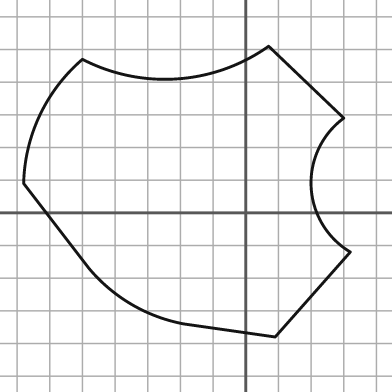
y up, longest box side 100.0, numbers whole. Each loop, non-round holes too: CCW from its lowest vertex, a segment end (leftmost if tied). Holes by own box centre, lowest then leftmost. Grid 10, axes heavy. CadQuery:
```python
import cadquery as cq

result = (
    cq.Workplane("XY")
    .moveTo(9.0, -38.0)
    .lineTo(32.0, -12.0)
    .threePointArc((20.0, 8.0), (30.0, 29.0))
    .lineTo(7.0, 51.0)
    .threePointArc((-21.0, 41.0), (-50.0, 47.0))
    .threePointArc((-63.0, 30.0), (-68.0, 9.0))
    .lineTo(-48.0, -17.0)
    .threePointArc((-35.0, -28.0), (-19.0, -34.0))
    .close()
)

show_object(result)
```